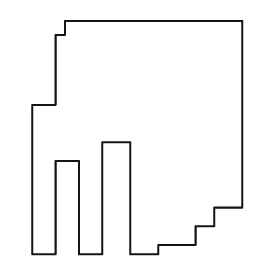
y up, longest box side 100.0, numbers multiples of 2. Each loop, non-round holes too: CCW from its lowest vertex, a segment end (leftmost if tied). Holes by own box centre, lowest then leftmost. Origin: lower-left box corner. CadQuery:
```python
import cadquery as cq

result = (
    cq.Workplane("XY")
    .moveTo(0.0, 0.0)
    .lineTo(10.0, 0.0)
    .lineTo(10.0, 40.0)
    .lineTo(20.0, 40.0)
    .lineTo(20.0, 0.0)
    .lineTo(30.0, 0.0)
    .lineTo(30.0, 48.0)
    .lineTo(42.0, 48.0)
    .lineTo(42.0, 0.0)
    .lineTo(54.0, 0.0)
    .lineTo(54.0, 4.0)
    .lineTo(70.0, 4.0)
    .lineTo(70.0, 12.0)
    .lineTo(78.0, 12.0)
    .lineTo(78.0, 20.0)
    .lineTo(90.0, 20.0)
    .lineTo(90.0, 100.0)
    .lineTo(14.0, 100.0)
    .lineTo(14.0, 94.0)
    .lineTo(10.0, 94.0)
    .lineTo(10.0, 64.0)
    .lineTo(0.0, 64.0)
    .close()
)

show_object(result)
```